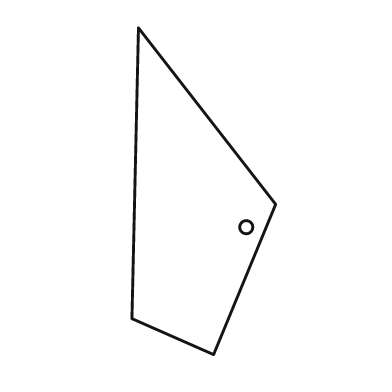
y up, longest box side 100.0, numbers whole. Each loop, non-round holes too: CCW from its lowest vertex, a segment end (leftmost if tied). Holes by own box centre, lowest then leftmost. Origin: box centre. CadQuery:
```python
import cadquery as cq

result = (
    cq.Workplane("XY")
    .moveTo(3.0, -50.0)
    .lineTo(22.0, -4.0)
    .lineTo(-20.0, 50.0)
    .lineTo(-22.0, -39.0)
    .close()
    .moveTo(13.0, -11.0)
    .circle(2.0)
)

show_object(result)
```